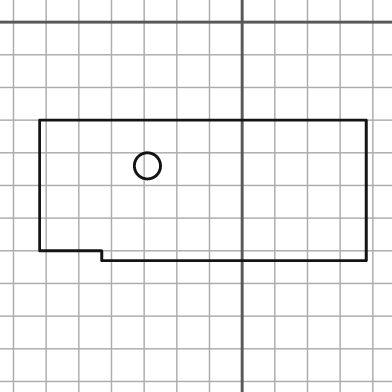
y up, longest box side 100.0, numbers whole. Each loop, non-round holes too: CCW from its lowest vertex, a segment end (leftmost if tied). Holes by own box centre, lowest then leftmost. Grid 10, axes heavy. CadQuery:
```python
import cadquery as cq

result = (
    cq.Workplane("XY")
    .moveTo(-43.0, -73.0)
    .lineTo(38.0, -73.0)
    .lineTo(38.0, -30.0)
    .lineTo(-62.0, -30.0)
    .lineTo(-62.0, -70.0)
    .lineTo(-43.0, -70.0)
    .close()
    .moveTo(-29.0, -44.0)
    .circle(4.0)
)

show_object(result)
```